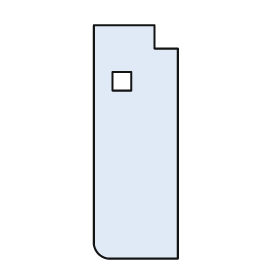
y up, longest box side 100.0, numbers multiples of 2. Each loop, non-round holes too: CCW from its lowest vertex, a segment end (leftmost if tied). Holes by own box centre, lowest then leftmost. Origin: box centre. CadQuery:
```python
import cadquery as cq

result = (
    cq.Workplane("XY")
    .moveTo(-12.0, -50.0)
    .lineTo(18.0, -50.0)
    .lineTo(18.0, 40.0)
    .lineTo(8.0, 40.0)
    .lineTo(8.0, 50.0)
    .lineTo(-18.0, 50.0)
    .lineTo(-18.0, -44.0)
    .threePointArc((-16.0, -48.0), (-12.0, -50.0))
    .close()
    .moveTo(-10.0, 22.0)
    .lineTo(-2.0, 22.0)
    .lineTo(-2.0, 30.0)
    .lineTo(-10.0, 30.0)
    .close()
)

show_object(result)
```